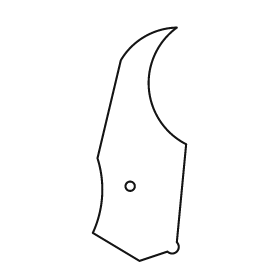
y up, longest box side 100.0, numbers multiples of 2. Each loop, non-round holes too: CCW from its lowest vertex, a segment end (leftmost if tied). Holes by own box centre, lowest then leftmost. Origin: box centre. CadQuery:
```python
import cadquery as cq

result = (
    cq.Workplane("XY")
    .moveTo(0.0, -50.0)
    .lineTo(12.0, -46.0)
    .threePointArc((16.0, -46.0), (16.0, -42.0))
    .lineTo(20.0, 0.0)
    .threePointArc((4.0, 24.0), (16.0, 50.0))
    .threePointArc((2.0, 46.0), (-8.0, 36.0))
    .lineTo(-18.0, -6.0)
    .threePointArc((-16.0, -22.0), (-20.0, -38.0))
    .close()
    .moveTo(-4.0, -18.0)
    .circle(2.0)
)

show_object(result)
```